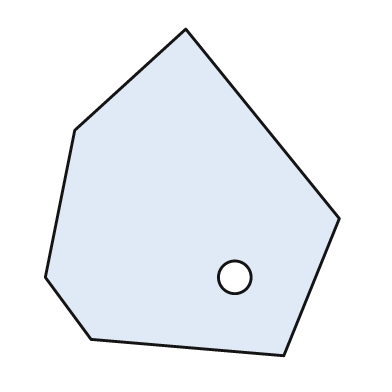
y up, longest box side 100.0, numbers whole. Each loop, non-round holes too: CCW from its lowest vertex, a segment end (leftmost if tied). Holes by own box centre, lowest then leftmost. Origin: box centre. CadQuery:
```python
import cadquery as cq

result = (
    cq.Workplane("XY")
    .moveTo(28.0, -50.0)
    .lineTo(45.0, -8.0)
    .lineTo(-2.0, 50.0)
    .lineTo(-36.0, 19.0)
    .lineTo(-45.0, -26.0)
    .lineTo(-31.0, -45.0)
    .close()
    .moveTo(13.0, -26.0)
    .circle(5.0)
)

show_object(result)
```